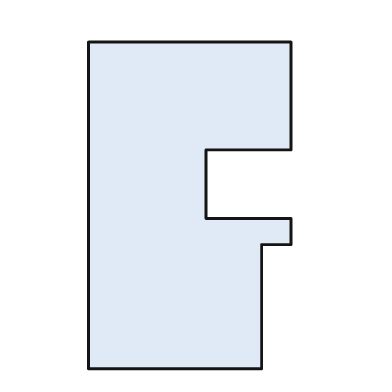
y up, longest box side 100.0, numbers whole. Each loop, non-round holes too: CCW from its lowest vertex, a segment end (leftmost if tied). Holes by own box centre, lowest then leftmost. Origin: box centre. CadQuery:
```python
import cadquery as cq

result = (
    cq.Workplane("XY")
    .moveTo(-31.0, -50.0)
    .lineTo(22.0, -50.0)
    .lineTo(22.0, -12.0)
    .lineTo(31.0, -12.0)
    .lineTo(31.0, -4.0)
    .lineTo(5.0, -4.0)
    .lineTo(5.0, 17.0)
    .lineTo(31.0, 17.0)
    .lineTo(31.0, 50.0)
    .lineTo(-31.0, 50.0)
    .close()
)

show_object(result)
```